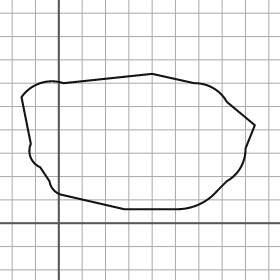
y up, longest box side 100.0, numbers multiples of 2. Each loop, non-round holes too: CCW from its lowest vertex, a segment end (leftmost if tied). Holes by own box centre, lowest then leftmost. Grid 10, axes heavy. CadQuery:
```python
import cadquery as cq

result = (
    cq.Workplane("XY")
    .moveTo(28.0, 6.0)
    .lineTo(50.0, 6.0)
    .threePointArc((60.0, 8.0), (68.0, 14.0))
    .lineTo(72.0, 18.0)
    .threePointArc((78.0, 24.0), (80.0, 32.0))
    .lineTo(84.0, 42.0)
    .lineTo(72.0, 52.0)
    .threePointArc((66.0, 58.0), (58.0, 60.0))
    .lineTo(40.0, 64.0)
    .lineTo(2.0, 60.0)
    .threePointArc((-8.0, 60.0), (-16.0, 54.0))
    .lineTo(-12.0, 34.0)
    .threePointArc((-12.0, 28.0), (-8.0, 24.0))
    .lineTo(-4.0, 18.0)
    .threePointArc((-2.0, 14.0), (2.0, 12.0))
    .close()
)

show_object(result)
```